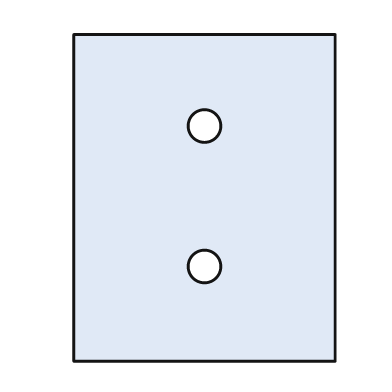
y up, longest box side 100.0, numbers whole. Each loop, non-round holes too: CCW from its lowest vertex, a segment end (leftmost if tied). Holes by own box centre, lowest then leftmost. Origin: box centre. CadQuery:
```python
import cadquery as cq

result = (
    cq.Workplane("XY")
    .moveTo(-40.0, -50.0)
    .lineTo(40.0, -50.0)
    .lineTo(40.0, 50.0)
    .lineTo(-40.0, 50.0)
    .close()
    .moveTo(0.0, -21.0)
    .circle(5.0)
    .moveTo(0.0, 22.0)
    .circle(5.0)
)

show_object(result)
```